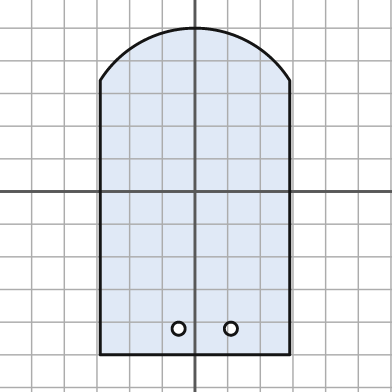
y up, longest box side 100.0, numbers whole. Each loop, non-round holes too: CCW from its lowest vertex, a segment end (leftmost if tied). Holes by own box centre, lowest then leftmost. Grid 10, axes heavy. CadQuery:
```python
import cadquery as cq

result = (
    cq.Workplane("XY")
    .moveTo(-29.0, -50.0)
    .lineTo(29.0, -50.0)
    .lineTo(29.0, 34.0)
    .threePointArc((0.0, 50.0), (-29.0, 34.0))
    .close()
    .moveTo(-5.0, -42.0)
    .circle(2.0)
    .moveTo(11.0, -42.0)
    .circle(2.0)
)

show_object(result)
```